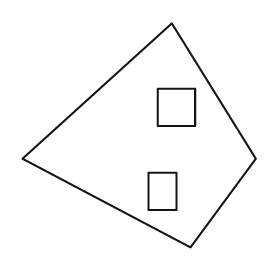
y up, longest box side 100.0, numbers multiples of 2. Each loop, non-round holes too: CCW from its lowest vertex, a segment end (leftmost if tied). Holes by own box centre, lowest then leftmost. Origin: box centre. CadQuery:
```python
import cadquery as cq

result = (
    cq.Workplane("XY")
    .moveTo(22.0, -48.0)
    .lineTo(50.0, -10.0)
    .lineTo(14.0, 48.0)
    .lineTo(-50.0, -10.0)
    .close()
    .moveTo(4.0, -32.0)
    .lineTo(16.0, -32.0)
    .lineTo(16.0, -16.0)
    .lineTo(4.0, -16.0)
    .close()
    .moveTo(8.0, 4.0)
    .lineTo(24.0, 4.0)
    .lineTo(24.0, 20.0)
    .lineTo(8.0, 20.0)
    .close()
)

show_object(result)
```